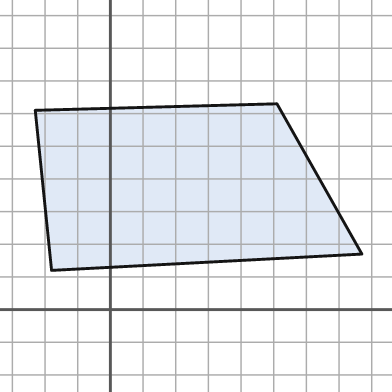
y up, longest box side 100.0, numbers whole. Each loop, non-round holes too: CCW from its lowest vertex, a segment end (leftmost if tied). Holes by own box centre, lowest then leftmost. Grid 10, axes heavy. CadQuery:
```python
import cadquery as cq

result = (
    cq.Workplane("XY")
    .moveTo(-18.0, 12.0)
    .lineTo(77.0, 17.0)
    .lineTo(51.0, 63.0)
    .lineTo(-23.0, 61.0)
    .close()
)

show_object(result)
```